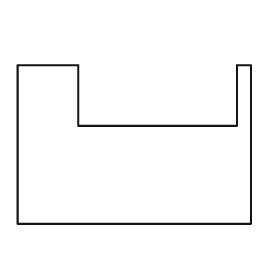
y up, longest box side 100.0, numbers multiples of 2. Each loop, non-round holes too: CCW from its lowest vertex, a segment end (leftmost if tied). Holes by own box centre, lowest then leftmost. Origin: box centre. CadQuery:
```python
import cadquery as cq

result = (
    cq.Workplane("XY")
    .moveTo(-50.0, -34.0)
    .lineTo(50.0, -34.0)
    .lineTo(50.0, 34.0)
    .lineTo(44.0, 34.0)
    .lineTo(44.0, 8.0)
    .lineTo(-24.0, 8.0)
    .lineTo(-24.0, 34.0)
    .lineTo(-50.0, 34.0)
    .close()
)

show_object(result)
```